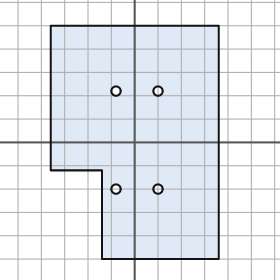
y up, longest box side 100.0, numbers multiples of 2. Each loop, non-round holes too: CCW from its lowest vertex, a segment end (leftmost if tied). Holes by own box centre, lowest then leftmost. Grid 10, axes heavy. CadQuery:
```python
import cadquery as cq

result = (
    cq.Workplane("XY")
    .moveTo(-14.0, -50.0)
    .lineTo(36.0, -50.0)
    .lineTo(36.0, 50.0)
    .lineTo(-36.0, 50.0)
    .lineTo(-36.0, -12.0)
    .lineTo(-14.0, -12.0)
    .close()
    .moveTo(-8.0, -20.0)
    .circle(2.0)
    .moveTo(10.0, -20.0)
    .circle(2.0)
    .moveTo(-8.0, 22.0)
    .circle(2.0)
    .moveTo(10.0, 22.0)
    .circle(2.0)
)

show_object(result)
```